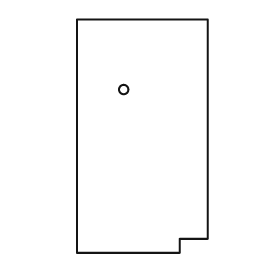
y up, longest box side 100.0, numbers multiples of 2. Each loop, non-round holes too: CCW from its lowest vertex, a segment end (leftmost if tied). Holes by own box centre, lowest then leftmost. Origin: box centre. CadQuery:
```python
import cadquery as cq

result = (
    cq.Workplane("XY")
    .moveTo(-28.0, -50.0)
    .lineTo(16.0, -50.0)
    .lineTo(16.0, -44.0)
    .lineTo(28.0, -44.0)
    .lineTo(28.0, 50.0)
    .lineTo(-28.0, 50.0)
    .close()
    .moveTo(-8.0, 20.0)
    .circle(2.0)
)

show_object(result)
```